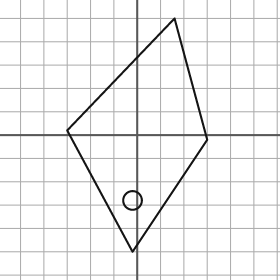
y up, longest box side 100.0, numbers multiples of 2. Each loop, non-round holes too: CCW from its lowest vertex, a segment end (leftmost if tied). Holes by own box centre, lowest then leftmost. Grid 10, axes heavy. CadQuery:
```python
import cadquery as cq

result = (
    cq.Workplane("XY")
    .moveTo(-2.0, -50.0)
    .lineTo(30.0, -2.0)
    .lineTo(16.0, 50.0)
    .lineTo(-30.0, 2.0)
    .close()
    .moveTo(-2.0, -28.0)
    .circle(4.0)
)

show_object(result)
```